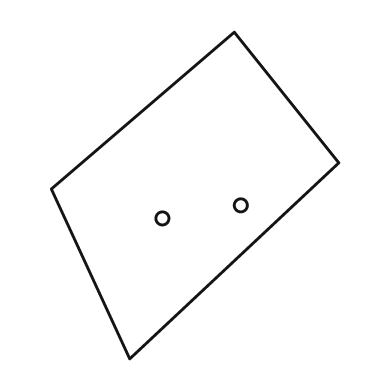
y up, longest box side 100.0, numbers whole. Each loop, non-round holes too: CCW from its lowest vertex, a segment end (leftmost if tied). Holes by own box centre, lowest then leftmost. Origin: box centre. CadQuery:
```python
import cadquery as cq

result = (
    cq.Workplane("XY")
    .moveTo(-20.0, -50.0)
    .lineTo(44.0, 10.0)
    .lineTo(12.0, 50.0)
    .lineTo(-44.0, 2.0)
    .close()
    .moveTo(-10.0, -7.0)
    .circle(2.0)
    .moveTo(14.0, -3.0)
    .circle(2.0)
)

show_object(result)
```